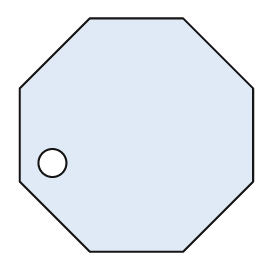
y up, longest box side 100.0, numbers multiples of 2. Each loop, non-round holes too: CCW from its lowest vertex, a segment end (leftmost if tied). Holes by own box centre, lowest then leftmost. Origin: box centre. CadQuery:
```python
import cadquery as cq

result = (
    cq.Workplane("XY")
    .moveTo(-20.0, -50.0)
    .lineTo(20.0, -50.0)
    .lineTo(50.0, -20.0)
    .lineTo(50.0, 20.0)
    .lineTo(20.0, 50.0)
    .lineTo(-20.0, 50.0)
    .lineTo(-50.0, 20.0)
    .lineTo(-50.0, -20.0)
    .close()
    .moveTo(-36.0, -12.0)
    .circle(6.0)
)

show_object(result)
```